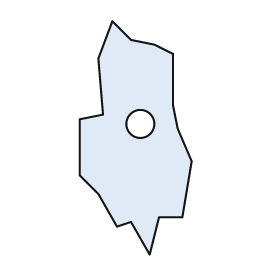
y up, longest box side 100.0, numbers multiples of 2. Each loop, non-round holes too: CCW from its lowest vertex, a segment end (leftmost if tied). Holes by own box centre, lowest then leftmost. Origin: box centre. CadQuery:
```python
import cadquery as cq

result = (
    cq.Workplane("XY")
    .moveTo(6.0, -50.0)
    .lineTo(10.0, -34.0)
    .lineTo(20.0, -34.0)
    .lineTo(24.0, -10.0)
    .lineTo(18.0, 4.0)
    .lineTo(16.0, 14.0)
    .lineTo(16.0, 36.0)
    .lineTo(8.0, 40.0)
    .lineTo(-2.0, 42.0)
    .lineTo(-10.0, 50.0)
    .lineTo(-16.0, 34.0)
    .lineTo(-14.0, 10.0)
    .lineTo(-24.0, 8.0)
    .lineTo(-24.0, -16.0)
    .lineTo(-16.0, -24.0)
    .lineTo(-8.0, -38.0)
    .lineTo(-2.0, -36.0)
    .close()
    .moveTo(2.0, 6.0)
    .circle(6.0)
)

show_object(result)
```